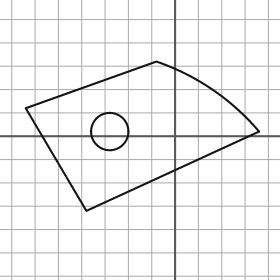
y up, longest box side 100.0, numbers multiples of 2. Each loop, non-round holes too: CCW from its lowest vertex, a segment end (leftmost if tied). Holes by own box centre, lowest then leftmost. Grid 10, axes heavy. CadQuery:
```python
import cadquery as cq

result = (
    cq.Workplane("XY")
    .moveTo(-38.0, -32.0)
    .lineTo(36.0, 2.0)
    .threePointArc((16.0, 20.0), (-8.0, 32.0))
    .lineTo(-64.0, 12.0)
    .close()
    .moveTo(-28.0, 2.0)
    .circle(8.0)
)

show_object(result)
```